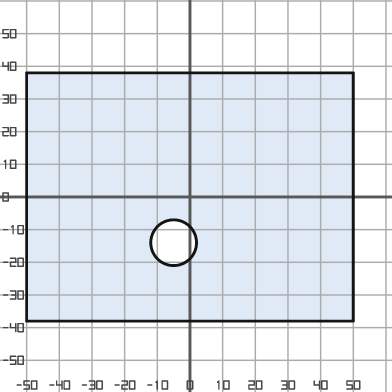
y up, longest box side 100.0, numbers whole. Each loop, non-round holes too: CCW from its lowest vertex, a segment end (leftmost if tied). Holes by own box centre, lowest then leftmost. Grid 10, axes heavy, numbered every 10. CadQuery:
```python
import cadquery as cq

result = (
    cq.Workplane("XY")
    .moveTo(-50.0, -38.0)
    .lineTo(50.0, -38.0)
    .lineTo(50.0, 38.0)
    .lineTo(-50.0, 38.0)
    .close()
    .moveTo(-5.0, -14.0)
    .circle(7.0)
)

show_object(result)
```